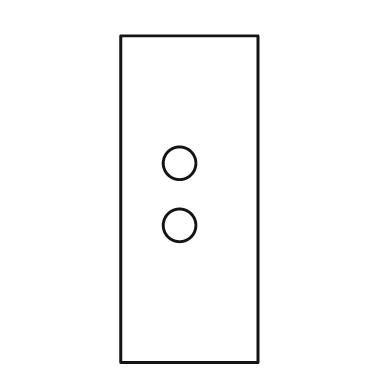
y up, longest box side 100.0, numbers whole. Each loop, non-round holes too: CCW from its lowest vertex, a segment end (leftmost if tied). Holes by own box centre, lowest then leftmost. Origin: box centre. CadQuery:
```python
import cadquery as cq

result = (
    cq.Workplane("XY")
    .moveTo(-21.0, -50.0)
    .lineTo(21.0, -50.0)
    .lineTo(21.0, 50.0)
    .lineTo(-21.0, 50.0)
    .close()
    .moveTo(-3.0, -8.0)
    .circle(5.0)
    .moveTo(-3.0, 11.0)
    .circle(5.0)
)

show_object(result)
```